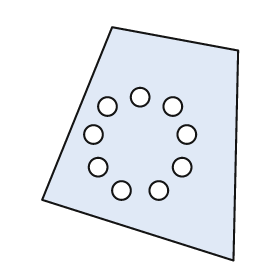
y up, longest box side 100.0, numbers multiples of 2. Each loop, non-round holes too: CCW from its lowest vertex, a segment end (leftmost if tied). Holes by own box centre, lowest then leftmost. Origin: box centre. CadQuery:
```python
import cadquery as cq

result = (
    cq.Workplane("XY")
    .moveTo(40.0, -50.0)
    .lineTo(42.0, 40.0)
    .lineTo(-12.0, 50.0)
    .lineTo(-42.0, -24.0)
    .close()
    .moveTo(-8.0, -20.0)
    .circle(4.0)
    .moveTo(8.0, -20.0)
    .circle(4.0)
    .moveTo(-18.0, -10.0)
    .circle(4.0)
    .moveTo(18.0, -10.0)
    .circle(4.0)
    .moveTo(-20.0, 4.0)
    .circle(4.0)
    .moveTo(20.0, 4.0)
    .circle(4.0)
    .moveTo(-14.0, 16.0)
    .circle(4.0)
    .moveTo(14.0, 16.0)
    .circle(4.0)
    .moveTo(0.0, 20.0)
    .circle(4.0)
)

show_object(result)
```